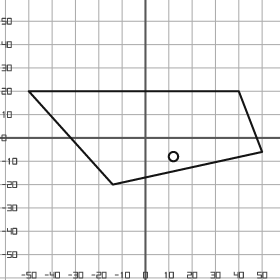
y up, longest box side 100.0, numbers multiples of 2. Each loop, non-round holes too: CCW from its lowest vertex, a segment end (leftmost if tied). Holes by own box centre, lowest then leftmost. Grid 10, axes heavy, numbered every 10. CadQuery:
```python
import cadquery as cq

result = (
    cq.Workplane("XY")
    .moveTo(-14.0, -20.0)
    .lineTo(50.0, -6.0)
    .lineTo(40.0, 20.0)
    .lineTo(-50.0, 20.0)
    .close()
    .moveTo(12.0, -8.0)
    .circle(2.0)
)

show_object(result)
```